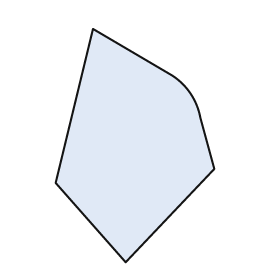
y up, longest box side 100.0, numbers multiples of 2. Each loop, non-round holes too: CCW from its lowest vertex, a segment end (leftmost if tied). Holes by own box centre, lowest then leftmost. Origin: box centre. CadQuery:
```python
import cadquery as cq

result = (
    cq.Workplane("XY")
    .moveTo(-4.0, -50.0)
    .lineTo(34.0, -10.0)
    .lineTo(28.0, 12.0)
    .threePointArc((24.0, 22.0), (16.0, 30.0))
    .lineTo(-18.0, 50.0)
    .lineTo(-34.0, -16.0)
    .close()
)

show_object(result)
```